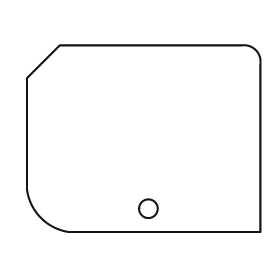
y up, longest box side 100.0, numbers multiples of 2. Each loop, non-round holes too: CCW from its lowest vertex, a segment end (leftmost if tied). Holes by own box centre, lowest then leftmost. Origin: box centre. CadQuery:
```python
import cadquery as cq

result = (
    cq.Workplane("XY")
    .moveTo(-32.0, -40.0)
    .lineTo(50.0, -40.0)
    .lineTo(50.0, 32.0)
    .threePointArc((48.0, 38.0), (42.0, 40.0))
    .lineTo(-36.0, 40.0)
    .lineTo(-50.0, 26.0)
    .lineTo(-50.0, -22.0)
    .threePointArc((-44.0, -34.0), (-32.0, -40.0))
    .close()
    .moveTo(2.0, -30.0)
    .circle(4.0)
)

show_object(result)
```